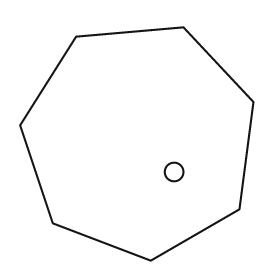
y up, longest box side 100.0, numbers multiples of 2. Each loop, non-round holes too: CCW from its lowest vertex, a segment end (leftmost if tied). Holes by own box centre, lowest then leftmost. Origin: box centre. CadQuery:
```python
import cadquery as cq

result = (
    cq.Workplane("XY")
    .moveTo(6.0, -50.0)
    .lineTo(44.0, -28.0)
    .lineTo(50.0, 18.0)
    .lineTo(20.0, 50.0)
    .lineTo(-26.0, 46.0)
    .lineTo(-50.0, 8.0)
    .lineTo(-36.0, -34.0)
    .close()
    .moveTo(16.0, -12.0)
    .circle(4.0)
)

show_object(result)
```